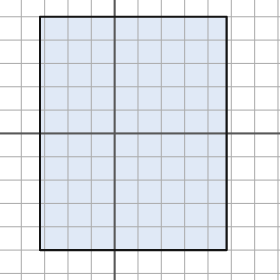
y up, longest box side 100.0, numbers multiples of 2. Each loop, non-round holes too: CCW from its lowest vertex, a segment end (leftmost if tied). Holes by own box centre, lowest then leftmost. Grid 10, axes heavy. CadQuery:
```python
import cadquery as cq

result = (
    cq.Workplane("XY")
    .moveTo(-32.0, -50.0)
    .lineTo(48.0, -50.0)
    .lineTo(48.0, 50.0)
    .lineTo(-32.0, 50.0)
    .close()
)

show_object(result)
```